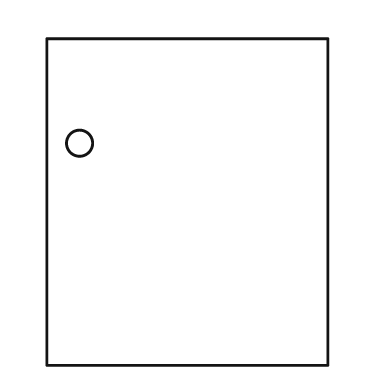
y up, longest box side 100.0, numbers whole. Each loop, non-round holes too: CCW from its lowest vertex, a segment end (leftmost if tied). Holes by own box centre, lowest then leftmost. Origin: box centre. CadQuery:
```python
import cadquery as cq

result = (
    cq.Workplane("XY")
    .moveTo(-43.0, -50.0)
    .lineTo(43.0, -50.0)
    .lineTo(43.0, 50.0)
    .lineTo(-43.0, 50.0)
    .close()
    .moveTo(-33.0, 18.0)
    .circle(4.0)
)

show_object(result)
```